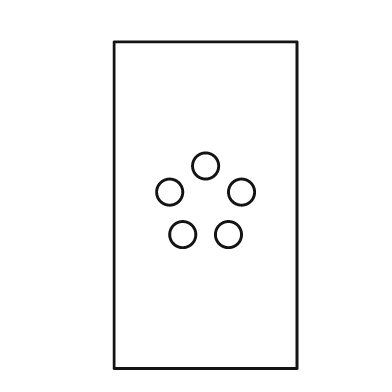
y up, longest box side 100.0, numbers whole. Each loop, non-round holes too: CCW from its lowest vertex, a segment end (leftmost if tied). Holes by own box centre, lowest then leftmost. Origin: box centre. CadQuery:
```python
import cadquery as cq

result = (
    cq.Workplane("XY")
    .moveTo(-28.0, -50.0)
    .lineTo(28.0, -50.0)
    .lineTo(28.0, 50.0)
    .lineTo(-28.0, 50.0)
    .close()
    .moveTo(-7.0, -9.0)
    .circle(4.0)
    .moveTo(7.0, -9.0)
    .circle(4.0)
    .moveTo(-11.0, 4.0)
    .circle(4.0)
    .moveTo(11.0, 4.0)
    .circle(4.0)
    .moveTo(0.0, 12.0)
    .circle(4.0)
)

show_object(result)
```